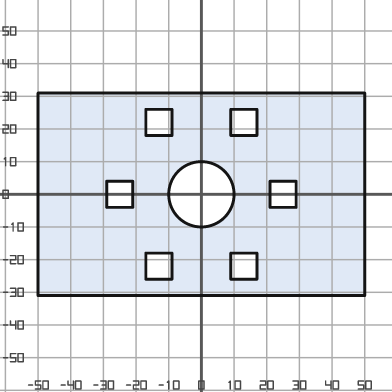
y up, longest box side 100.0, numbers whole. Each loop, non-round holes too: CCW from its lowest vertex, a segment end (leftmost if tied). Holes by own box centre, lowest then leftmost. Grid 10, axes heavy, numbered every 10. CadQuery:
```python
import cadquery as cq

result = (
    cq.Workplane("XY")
    .moveTo(-50.0, -31.0)
    .lineTo(50.0, -31.0)
    .lineTo(50.0, 31.0)
    .lineTo(-50.0, 31.0)
    .close()
    .moveTo(-17.0, -26.0)
    .lineTo(-9.0, -26.0)
    .lineTo(-9.0, -18.0)
    .lineTo(-17.0, -18.0)
    .close()
    .moveTo(9.0, -26.0)
    .lineTo(17.0, -26.0)
    .lineTo(17.0, -18.0)
    .lineTo(9.0, -18.0)
    .close()
    .moveTo(-29.0, -4.0)
    .lineTo(-21.0, -4.0)
    .lineTo(-21.0, 4.0)
    .lineTo(-29.0, 4.0)
    .close()
    .moveTo(0.0, 0.0)
    .circle(10.0)
    .moveTo(21.0, -4.0)
    .lineTo(29.0, -4.0)
    .lineTo(29.0, 4.0)
    .lineTo(21.0, 4.0)
    .close()
    .moveTo(-17.0, 18.0)
    .lineTo(-9.0, 18.0)
    .lineTo(-9.0, 26.0)
    .lineTo(-17.0, 26.0)
    .close()
    .moveTo(9.0, 18.0)
    .lineTo(17.0, 18.0)
    .lineTo(17.0, 26.0)
    .lineTo(9.0, 26.0)
    .close()
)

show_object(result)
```